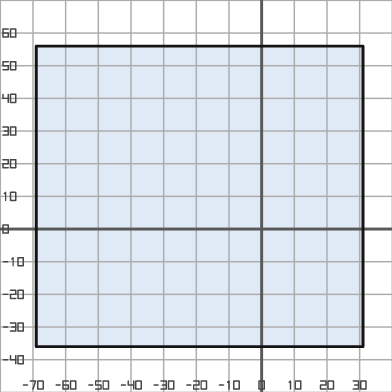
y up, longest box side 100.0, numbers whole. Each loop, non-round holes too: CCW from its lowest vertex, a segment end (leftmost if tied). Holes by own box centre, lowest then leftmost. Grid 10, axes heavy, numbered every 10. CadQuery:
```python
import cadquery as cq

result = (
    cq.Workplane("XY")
    .moveTo(-69.0, -36.0)
    .lineTo(31.0, -36.0)
    .lineTo(31.0, 56.0)
    .lineTo(-69.0, 56.0)
    .close()
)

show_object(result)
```